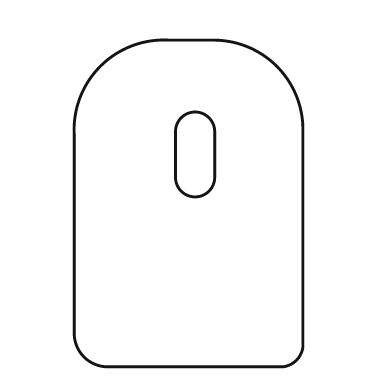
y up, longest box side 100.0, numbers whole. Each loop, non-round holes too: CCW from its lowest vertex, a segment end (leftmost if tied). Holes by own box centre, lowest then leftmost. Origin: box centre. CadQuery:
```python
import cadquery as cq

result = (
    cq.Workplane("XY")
    .moveTo(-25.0, -50.0)
    .lineTo(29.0, -50.0)
    .threePointArc((33.0, -48.0), (35.0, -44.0))
    .lineTo(35.0, 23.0)
    .threePointArc((27.0, 42.0), (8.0, 50.0))
    .lineTo(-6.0, 50.0)
    .threePointArc((-27.0, 42.0), (-35.0, 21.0))
    .lineTo(-35.0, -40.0)
    .threePointArc((-32.0, -47.0), (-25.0, -50.0))
    .close()
    .moveTo(-4.0, 8.0)
    .threePointArc((2.0, 2.0), (8.0, 8.0))
    .lineTo(8.0, 22.0)
    .threePointArc((2.0, 28.0), (-4.0, 22.0))
    .close()
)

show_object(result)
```